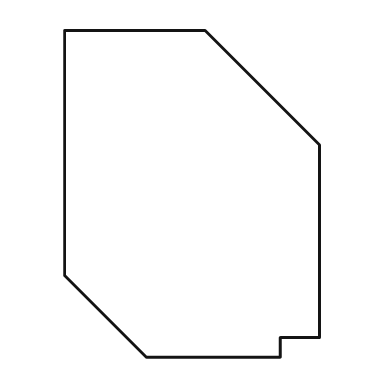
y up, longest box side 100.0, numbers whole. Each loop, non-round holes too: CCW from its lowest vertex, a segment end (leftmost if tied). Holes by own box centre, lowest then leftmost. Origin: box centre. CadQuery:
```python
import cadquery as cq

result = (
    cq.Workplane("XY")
    .moveTo(-14.0, -50.0)
    .lineTo(27.0, -50.0)
    .lineTo(27.0, -44.0)
    .lineTo(39.0, -44.0)
    .lineTo(39.0, 15.0)
    .lineTo(4.0, 50.0)
    .lineTo(-39.0, 50.0)
    .lineTo(-39.0, -25.0)
    .close()
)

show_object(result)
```